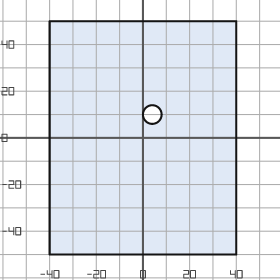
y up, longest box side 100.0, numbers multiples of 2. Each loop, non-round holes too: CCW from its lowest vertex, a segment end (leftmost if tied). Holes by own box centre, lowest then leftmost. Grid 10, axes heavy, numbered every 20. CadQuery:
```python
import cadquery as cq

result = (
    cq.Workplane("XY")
    .moveTo(-40.0, -50.0)
    .lineTo(40.0, -50.0)
    .lineTo(40.0, 50.0)
    .lineTo(-40.0, 50.0)
    .close()
    .moveTo(4.0, 10.0)
    .circle(4.0)
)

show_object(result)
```